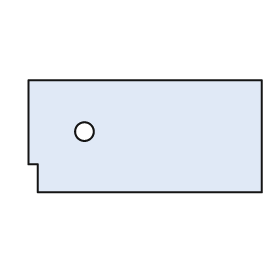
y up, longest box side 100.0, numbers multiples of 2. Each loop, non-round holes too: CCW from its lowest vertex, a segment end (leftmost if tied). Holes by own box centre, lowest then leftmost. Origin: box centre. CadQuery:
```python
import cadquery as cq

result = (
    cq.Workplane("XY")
    .moveTo(-46.0, -24.0)
    .lineTo(50.0, -24.0)
    .lineTo(50.0, 24.0)
    .lineTo(-50.0, 24.0)
    .lineTo(-50.0, -12.0)
    .lineTo(-46.0, -12.0)
    .close()
    .moveTo(-26.0, 2.0)
    .circle(4.0)
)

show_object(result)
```